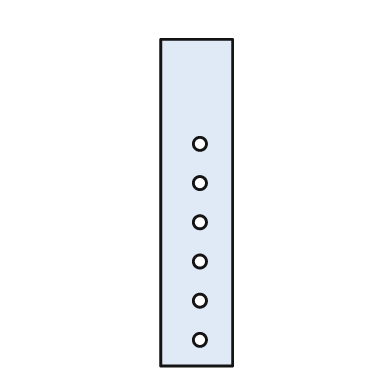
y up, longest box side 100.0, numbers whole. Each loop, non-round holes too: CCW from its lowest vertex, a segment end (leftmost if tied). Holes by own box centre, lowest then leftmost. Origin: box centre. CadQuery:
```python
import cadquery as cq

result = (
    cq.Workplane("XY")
    .moveTo(-11.0, -50.0)
    .lineTo(11.0, -50.0)
    .lineTo(11.0, 50.0)
    .lineTo(-11.0, 50.0)
    .close()
    .moveTo(1.0, -42.0)
    .circle(2.0)
    .moveTo(1.0, -30.0)
    .circle(2.0)
    .moveTo(1.0, -18.0)
    .circle(2.0)
    .moveTo(1.0, -6.0)
    .circle(2.0)
    .moveTo(1.0, 6.0)
    .circle(2.0)
    .moveTo(1.0, 18.0)
    .circle(2.0)
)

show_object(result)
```